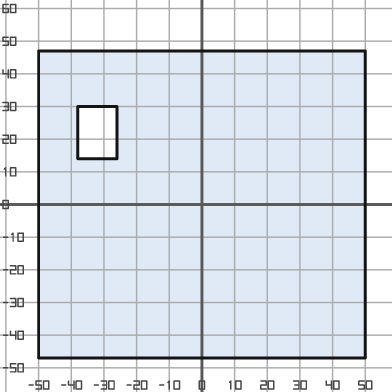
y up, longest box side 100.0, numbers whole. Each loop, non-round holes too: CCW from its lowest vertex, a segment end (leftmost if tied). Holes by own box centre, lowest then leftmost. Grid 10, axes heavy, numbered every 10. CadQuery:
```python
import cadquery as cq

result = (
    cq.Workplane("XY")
    .moveTo(-50.0, -47.0)
    .lineTo(50.0, -47.0)
    .lineTo(50.0, 47.0)
    .lineTo(-50.0, 47.0)
    .close()
    .moveTo(-38.0, 14.0)
    .lineTo(-26.0, 14.0)
    .lineTo(-26.0, 30.0)
    .lineTo(-38.0, 30.0)
    .close()
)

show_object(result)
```